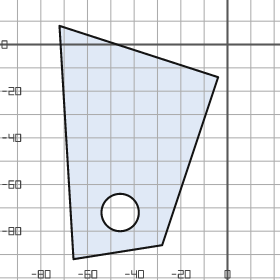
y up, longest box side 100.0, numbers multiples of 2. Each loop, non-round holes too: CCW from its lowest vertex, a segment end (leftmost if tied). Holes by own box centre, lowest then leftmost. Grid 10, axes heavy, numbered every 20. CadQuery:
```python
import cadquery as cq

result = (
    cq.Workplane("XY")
    .moveTo(-66.0, -92.0)
    .lineTo(-28.0, -86.0)
    .lineTo(-4.0, -14.0)
    .lineTo(-72.0, 8.0)
    .close()
    .moveTo(-46.0, -72.0)
    .circle(8.0)
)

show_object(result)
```